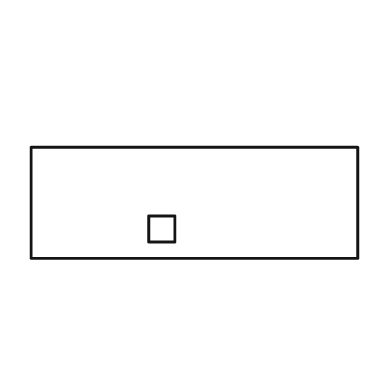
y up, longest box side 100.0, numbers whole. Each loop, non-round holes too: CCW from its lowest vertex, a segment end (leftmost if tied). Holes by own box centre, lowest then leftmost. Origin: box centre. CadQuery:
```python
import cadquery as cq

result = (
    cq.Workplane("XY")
    .moveTo(-50.0, -17.0)
    .lineTo(50.0, -17.0)
    .lineTo(50.0, 17.0)
    .lineTo(-50.0, 17.0)
    .close()
    .moveTo(-14.0, -12.0)
    .lineTo(-6.0, -12.0)
    .lineTo(-6.0, -4.0)
    .lineTo(-14.0, -4.0)
    .close()
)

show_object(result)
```